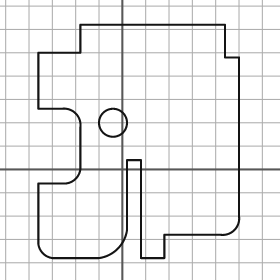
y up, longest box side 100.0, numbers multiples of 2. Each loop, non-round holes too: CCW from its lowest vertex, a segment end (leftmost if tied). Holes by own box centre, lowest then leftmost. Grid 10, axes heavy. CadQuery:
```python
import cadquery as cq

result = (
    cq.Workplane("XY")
    .moveTo(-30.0, -38.0)
    .lineTo(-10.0, -38.0)
    .threePointArc((-2.0, -34.0), (2.0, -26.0))
    .lineTo(2.0, 4.0)
    .lineTo(8.0, 4.0)
    .lineTo(8.0, -38.0)
    .lineTo(18.0, -38.0)
    .lineTo(18.0, -28.0)
    .lineTo(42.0, -28.0)
    .threePointArc((48.0, -26.0), (50.0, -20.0))
    .lineTo(50.0, 48.0)
    .lineTo(44.0, 48.0)
    .lineTo(44.0, 62.0)
    .lineTo(-18.0, 62.0)
    .lineTo(-18.0, 50.0)
    .lineTo(-36.0, 50.0)
    .lineTo(-36.0, 26.0)
    .lineTo(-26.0, 26.0)
    .threePointArc((-20.0, 24.0), (-18.0, 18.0))
    .lineTo(-18.0, 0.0)
    .threePointArc((-20.0, -4.0), (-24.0, -6.0))
    .lineTo(-36.0, -6.0)
    .lineTo(-36.0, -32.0)
    .threePointArc((-34.0, -36.0), (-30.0, -38.0))
    .close()
    .moveTo(-4.0, 20.0)
    .circle(6.0)
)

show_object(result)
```